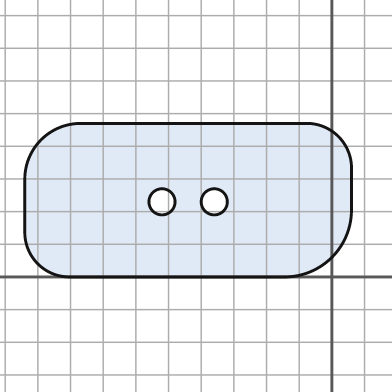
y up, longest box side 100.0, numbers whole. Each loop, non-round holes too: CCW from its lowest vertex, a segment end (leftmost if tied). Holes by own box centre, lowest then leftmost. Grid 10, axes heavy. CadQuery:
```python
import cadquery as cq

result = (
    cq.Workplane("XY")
    .moveTo(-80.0, 0.0)
    .lineTo(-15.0, 0.0)
    .threePointArc((0.0, 6.0), (6.0, 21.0))
    .lineTo(6.0, 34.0)
    .threePointArc((2.0, 43.0), (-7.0, 47.0))
    .lineTo(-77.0, 47.0)
    .threePointArc((-89.0, 42.0), (-94.0, 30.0))
    .lineTo(-94.0, 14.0)
    .threePointArc((-90.0, 4.0), (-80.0, 0.0))
    .close()
    .moveTo(-52.0, 23.0)
    .circle(4.0)
    .moveTo(-36.0, 23.0)
    .circle(4.0)
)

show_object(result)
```